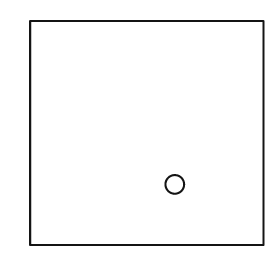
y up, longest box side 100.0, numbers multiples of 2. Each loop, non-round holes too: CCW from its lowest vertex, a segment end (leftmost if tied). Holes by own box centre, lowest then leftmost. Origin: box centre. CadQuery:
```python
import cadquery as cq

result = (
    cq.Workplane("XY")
    .moveTo(-50.0, -48.0)
    .lineTo(50.0, -48.0)
    .lineTo(50.0, 48.0)
    .lineTo(-50.0, 48.0)
    .close()
    .moveTo(12.0, -22.0)
    .circle(4.0)
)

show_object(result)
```